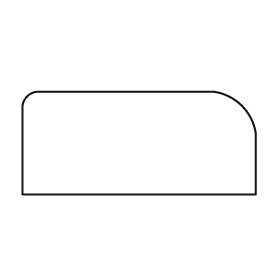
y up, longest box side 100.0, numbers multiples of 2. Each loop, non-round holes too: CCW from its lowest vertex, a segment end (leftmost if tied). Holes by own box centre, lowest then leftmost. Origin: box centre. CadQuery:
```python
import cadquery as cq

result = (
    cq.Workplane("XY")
    .moveTo(-50.0, -22.0)
    .lineTo(50.0, -22.0)
    .lineTo(50.0, 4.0)
    .threePointArc((44.0, 16.0), (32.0, 22.0))
    .lineTo(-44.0, 22.0)
    .threePointArc((-48.0, 20.0), (-50.0, 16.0))
    .close()
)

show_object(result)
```